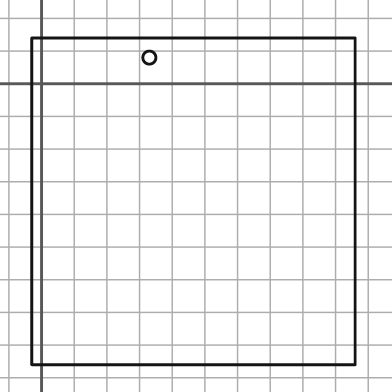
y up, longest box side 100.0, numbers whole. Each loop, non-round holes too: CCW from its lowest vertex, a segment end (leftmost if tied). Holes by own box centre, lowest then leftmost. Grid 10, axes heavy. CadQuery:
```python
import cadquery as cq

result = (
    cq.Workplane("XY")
    .moveTo(-3.0, -86.0)
    .lineTo(96.0, -86.0)
    .lineTo(96.0, 14.0)
    .lineTo(-3.0, 14.0)
    .close()
    .moveTo(33.0, 8.0)
    .circle(2.0)
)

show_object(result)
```